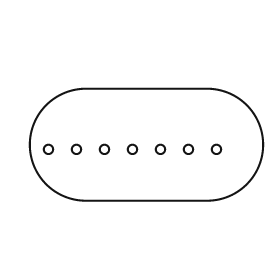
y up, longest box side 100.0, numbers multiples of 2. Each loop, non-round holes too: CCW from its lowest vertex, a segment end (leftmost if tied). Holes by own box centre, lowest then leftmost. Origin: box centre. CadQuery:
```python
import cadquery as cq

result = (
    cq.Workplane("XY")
    .moveTo(-26.0, -24.0)
    .lineTo(26.0, -24.0)
    .threePointArc((50.0, 0.0), (26.0, 24.0))
    .lineTo(-26.0, 24.0)
    .threePointArc((-50.0, 0.0), (-26.0, -24.0))
    .close()
    .moveTo(-42.0, -2.0)
    .circle(2.0)
    .moveTo(-30.0, -2.0)
    .circle(2.0)
    .moveTo(-18.0, -2.0)
    .circle(2.0)
    .moveTo(-6.0, -2.0)
    .circle(2.0)
    .moveTo(6.0, -2.0)
    .circle(2.0)
    .moveTo(18.0, -2.0)
    .circle(2.0)
    .moveTo(30.0, -2.0)
    .circle(2.0)
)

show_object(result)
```